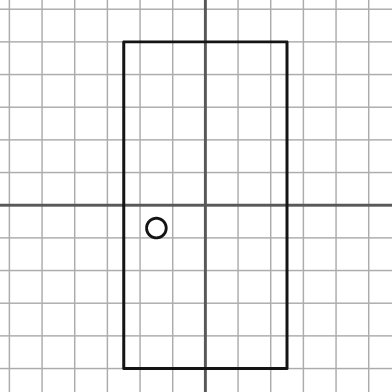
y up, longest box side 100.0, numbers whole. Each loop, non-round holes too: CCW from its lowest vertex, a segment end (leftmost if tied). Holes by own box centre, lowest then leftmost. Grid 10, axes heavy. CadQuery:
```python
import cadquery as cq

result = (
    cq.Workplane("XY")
    .moveTo(-25.0, -50.0)
    .lineTo(25.0, -50.0)
    .lineTo(25.0, 50.0)
    .lineTo(-25.0, 50.0)
    .close()
    .moveTo(-15.0, -7.0)
    .circle(3.0)
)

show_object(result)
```